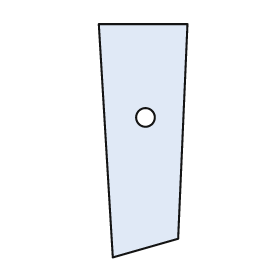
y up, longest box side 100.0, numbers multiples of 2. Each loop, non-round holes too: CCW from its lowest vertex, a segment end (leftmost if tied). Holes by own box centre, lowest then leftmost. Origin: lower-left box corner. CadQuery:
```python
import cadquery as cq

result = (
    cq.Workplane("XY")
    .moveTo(6.0, 0.0)
    .lineTo(34.0, 8.0)
    .lineTo(38.0, 100.0)
    .lineTo(0.0, 100.0)
    .close()
    .moveTo(20.0, 60.0)
    .circle(4.0)
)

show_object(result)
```